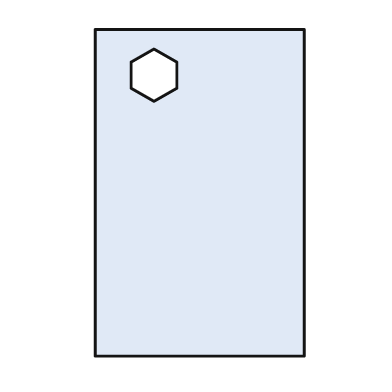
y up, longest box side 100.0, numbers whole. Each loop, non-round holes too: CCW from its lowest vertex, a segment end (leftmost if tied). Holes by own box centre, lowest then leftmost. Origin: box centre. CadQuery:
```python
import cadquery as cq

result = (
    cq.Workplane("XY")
    .moveTo(-32.0, -50.0)
    .lineTo(32.0, -50.0)
    .lineTo(32.0, 50.0)
    .lineTo(-32.0, 50.0)
    .close()
    .moveTo(-14.0, 28.0)
    .lineTo(-7.0, 32.0)
    .lineTo(-7.0, 40.0)
    .lineTo(-14.0, 44.0)
    .lineTo(-21.0, 40.0)
    .lineTo(-21.0, 32.0)
    .close()
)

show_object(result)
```